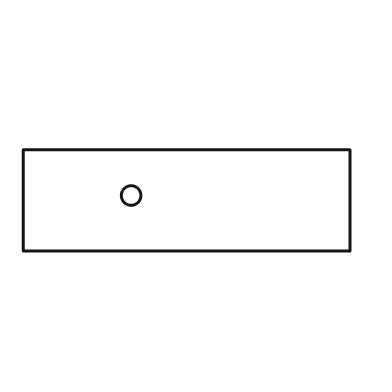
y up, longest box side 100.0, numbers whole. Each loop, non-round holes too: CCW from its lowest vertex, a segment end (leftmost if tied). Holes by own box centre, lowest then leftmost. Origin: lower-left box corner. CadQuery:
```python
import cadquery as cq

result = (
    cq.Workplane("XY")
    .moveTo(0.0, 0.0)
    .lineTo(100.0, 0.0)
    .lineTo(100.0, 31.0)
    .lineTo(0.0, 31.0)
    .close()
    .moveTo(33.0, 17.0)
    .circle(3.0)
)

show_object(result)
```